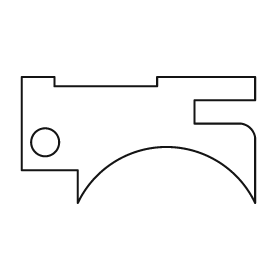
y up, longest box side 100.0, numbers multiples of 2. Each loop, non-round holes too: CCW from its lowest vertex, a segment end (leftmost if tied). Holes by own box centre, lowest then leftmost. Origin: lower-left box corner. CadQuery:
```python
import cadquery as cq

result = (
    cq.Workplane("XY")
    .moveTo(24.0, 0.0)
    .threePointArc((62.0, 24.0), (100.0, 0.0))
    .lineTo(100.0, 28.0)
    .threePointArc((98.0, 32.0), (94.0, 34.0))
    .lineTo(74.0, 34.0)
    .lineTo(74.0, 44.0)
    .lineTo(100.0, 44.0)
    .lineTo(100.0, 54.0)
    .lineTo(58.0, 54.0)
    .lineTo(58.0, 50.0)
    .lineTo(14.0, 50.0)
    .lineTo(14.0, 54.0)
    .lineTo(0.0, 54.0)
    .lineTo(0.0, 14.0)
    .lineTo(24.0, 14.0)
    .close()
    .moveTo(10.0, 26.0)
    .circle(6.0)
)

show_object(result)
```